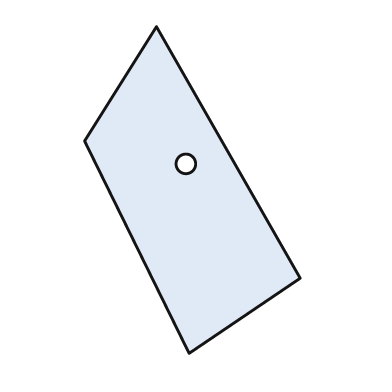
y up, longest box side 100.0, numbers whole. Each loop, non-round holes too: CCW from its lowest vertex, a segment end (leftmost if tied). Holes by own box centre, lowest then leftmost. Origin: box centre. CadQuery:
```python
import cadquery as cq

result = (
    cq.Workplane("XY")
    .moveTo(-1.0, -50.0)
    .lineTo(33.0, -27.0)
    .lineTo(-11.0, 50.0)
    .lineTo(-33.0, 15.0)
    .close()
    .moveTo(-2.0, 8.0)
    .circle(3.0)
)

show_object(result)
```